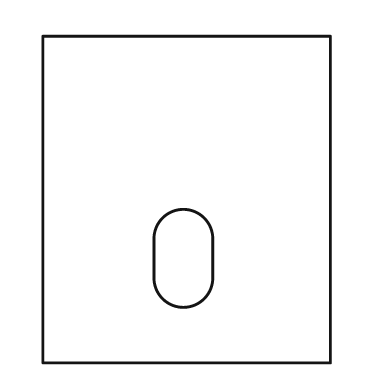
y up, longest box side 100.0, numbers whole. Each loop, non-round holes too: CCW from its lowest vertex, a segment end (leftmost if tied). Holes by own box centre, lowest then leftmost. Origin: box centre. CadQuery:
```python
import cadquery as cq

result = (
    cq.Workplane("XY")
    .moveTo(-44.0, -50.0)
    .lineTo(44.0, -50.0)
    .lineTo(44.0, 50.0)
    .lineTo(-44.0, 50.0)
    .close()
    .moveTo(-10.0, -24.0)
    .threePointArc((-1.0, -33.0), (8.0, -24.0))
    .lineTo(8.0, -12.0)
    .threePointArc((-1.0, -3.0), (-10.0, -12.0))
    .close()
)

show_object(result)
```